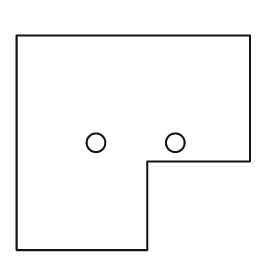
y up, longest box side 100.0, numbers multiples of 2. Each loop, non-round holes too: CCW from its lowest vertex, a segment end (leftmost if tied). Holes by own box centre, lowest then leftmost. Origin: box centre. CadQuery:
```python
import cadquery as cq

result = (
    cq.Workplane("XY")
    .moveTo(-50.0, -46.0)
    .lineTo(6.0, -46.0)
    .lineTo(6.0, -8.0)
    .lineTo(50.0, -8.0)
    .lineTo(50.0, 46.0)
    .lineTo(-50.0, 46.0)
    .close()
    .moveTo(-16.0, 0.0)
    .circle(4.0)
    .moveTo(18.0, 0.0)
    .circle(4.0)
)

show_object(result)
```